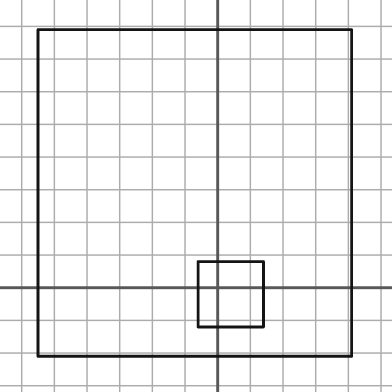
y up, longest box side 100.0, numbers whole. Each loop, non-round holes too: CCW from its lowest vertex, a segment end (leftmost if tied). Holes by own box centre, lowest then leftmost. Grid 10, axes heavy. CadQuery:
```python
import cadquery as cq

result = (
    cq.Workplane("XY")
    .moveTo(-55.0, -21.0)
    .lineTo(41.0, -21.0)
    .lineTo(41.0, 79.0)
    .lineTo(-55.0, 79.0)
    .close()
    .moveTo(-6.0, -12.0)
    .lineTo(14.0, -12.0)
    .lineTo(14.0, 8.0)
    .lineTo(-6.0, 8.0)
    .close()
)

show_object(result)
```